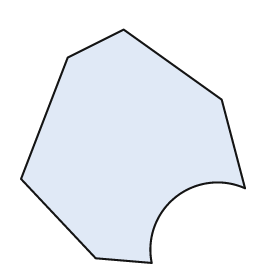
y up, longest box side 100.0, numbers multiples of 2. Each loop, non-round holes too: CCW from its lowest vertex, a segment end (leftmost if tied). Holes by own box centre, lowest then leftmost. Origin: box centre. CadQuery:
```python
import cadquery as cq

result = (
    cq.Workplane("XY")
    .moveTo(8.0, -50.0)
    .threePointArc((18.0, -22.0), (48.0, -18.0))
    .lineTo(38.0, 20.0)
    .lineTo(-4.0, 50.0)
    .lineTo(-28.0, 38.0)
    .lineTo(-48.0, -14.0)
    .lineTo(-16.0, -48.0)
    .close()
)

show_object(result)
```